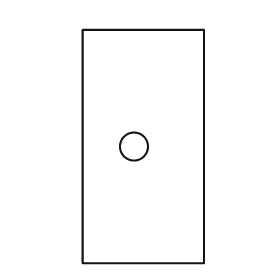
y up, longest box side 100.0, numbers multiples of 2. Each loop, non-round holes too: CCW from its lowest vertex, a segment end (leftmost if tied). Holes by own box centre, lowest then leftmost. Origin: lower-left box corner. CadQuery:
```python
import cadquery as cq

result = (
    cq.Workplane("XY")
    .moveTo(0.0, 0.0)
    .lineTo(52.0, 0.0)
    .lineTo(52.0, 100.0)
    .lineTo(0.0, 100.0)
    .close()
    .moveTo(22.0, 50.0)
    .circle(6.0)
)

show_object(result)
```